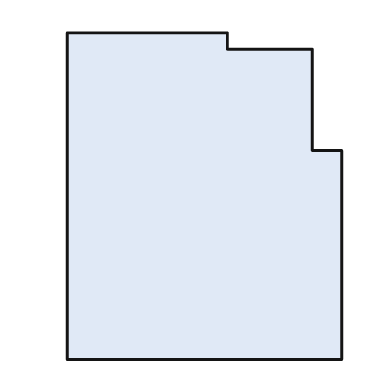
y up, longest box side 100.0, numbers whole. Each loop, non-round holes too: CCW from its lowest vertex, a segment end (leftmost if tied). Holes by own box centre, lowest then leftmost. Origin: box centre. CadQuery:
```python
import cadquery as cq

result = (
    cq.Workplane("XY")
    .moveTo(-42.0, -50.0)
    .lineTo(42.0, -50.0)
    .lineTo(42.0, 14.0)
    .lineTo(33.0, 14.0)
    .lineTo(33.0, 45.0)
    .lineTo(7.0, 45.0)
    .lineTo(7.0, 50.0)
    .lineTo(-42.0, 50.0)
    .close()
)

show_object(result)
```